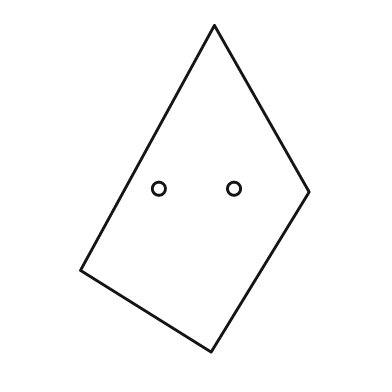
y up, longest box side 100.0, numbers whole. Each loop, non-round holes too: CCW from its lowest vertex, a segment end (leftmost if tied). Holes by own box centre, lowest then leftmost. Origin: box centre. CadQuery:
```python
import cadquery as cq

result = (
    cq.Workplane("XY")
    .moveTo(5.0, -50.0)
    .lineTo(35.0, -1.0)
    .lineTo(6.0, 50.0)
    .lineTo(-35.0, -25.0)
    .close()
    .moveTo(-11.0, 0.0)
    .circle(2.0)
    .moveTo(12.0, 0.0)
    .circle(2.0)
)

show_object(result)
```